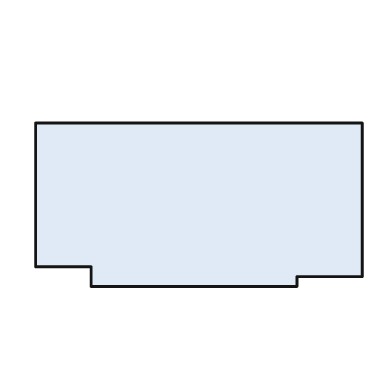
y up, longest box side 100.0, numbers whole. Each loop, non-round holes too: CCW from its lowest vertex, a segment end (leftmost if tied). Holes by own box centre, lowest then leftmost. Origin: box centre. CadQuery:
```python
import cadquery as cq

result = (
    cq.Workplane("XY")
    .moveTo(-33.0, -25.0)
    .lineTo(30.0, -25.0)
    .lineTo(30.0, -22.0)
    .lineTo(50.0, -22.0)
    .lineTo(50.0, 25.0)
    .lineTo(-50.0, 25.0)
    .lineTo(-50.0, -19.0)
    .lineTo(-33.0, -19.0)
    .close()
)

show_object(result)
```